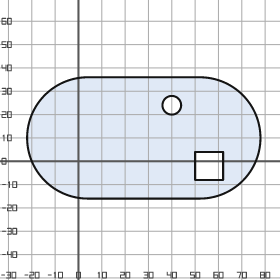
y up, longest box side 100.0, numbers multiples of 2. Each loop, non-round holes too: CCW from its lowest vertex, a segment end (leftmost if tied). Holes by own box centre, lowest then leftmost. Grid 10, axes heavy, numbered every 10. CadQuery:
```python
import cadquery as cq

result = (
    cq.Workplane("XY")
    .moveTo(4.0, -16.0)
    .lineTo(52.0, -16.0)
    .threePointArc((78.0, 10.0), (52.0, 36.0))
    .lineTo(4.0, 36.0)
    .threePointArc((-22.0, 10.0), (4.0, -16.0))
    .close()
    .moveTo(50.0, -8.0)
    .lineTo(62.0, -8.0)
    .lineTo(62.0, 4.0)
    .lineTo(50.0, 4.0)
    .close()
    .moveTo(40.0, 24.0)
    .circle(4.0)
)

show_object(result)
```